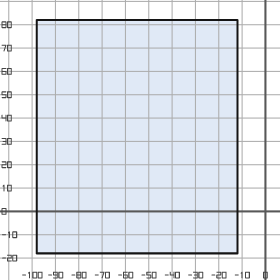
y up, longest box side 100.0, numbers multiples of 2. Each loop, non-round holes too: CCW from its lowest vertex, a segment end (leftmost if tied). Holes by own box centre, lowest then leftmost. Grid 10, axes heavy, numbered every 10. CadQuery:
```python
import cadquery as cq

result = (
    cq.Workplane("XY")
    .moveTo(-98.0, -18.0)
    .lineTo(-12.0, -18.0)
    .lineTo(-12.0, 82.0)
    .lineTo(-98.0, 82.0)
    .close()
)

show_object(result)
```